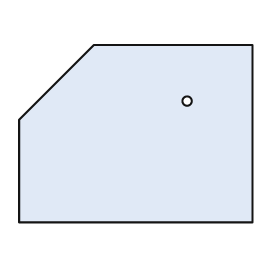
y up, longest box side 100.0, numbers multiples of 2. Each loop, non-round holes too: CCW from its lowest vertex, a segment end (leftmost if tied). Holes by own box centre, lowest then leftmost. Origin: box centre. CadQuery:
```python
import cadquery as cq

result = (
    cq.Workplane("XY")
    .moveTo(-50.0, -38.0)
    .lineTo(50.0, -38.0)
    .lineTo(50.0, 38.0)
    .lineTo(-18.0, 38.0)
    .lineTo(-50.0, 6.0)
    .close()
    .moveTo(22.0, 14.0)
    .circle(2.0)
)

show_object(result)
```